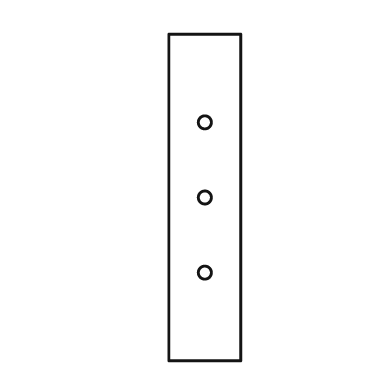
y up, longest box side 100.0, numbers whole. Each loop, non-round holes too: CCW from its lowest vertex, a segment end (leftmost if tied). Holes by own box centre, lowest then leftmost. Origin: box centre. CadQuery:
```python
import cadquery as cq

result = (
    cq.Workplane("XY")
    .moveTo(-11.0, -50.0)
    .lineTo(11.0, -50.0)
    .lineTo(11.0, 50.0)
    .lineTo(-11.0, 50.0)
    .close()
    .moveTo(0.0, -23.0)
    .circle(2.0)
    .moveTo(0.0, 0.0)
    .circle(2.0)
    .moveTo(0.0, 23.0)
    .circle(2.0)
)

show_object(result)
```